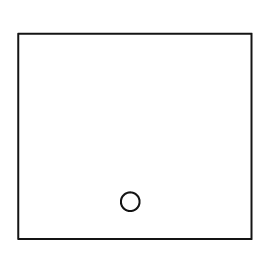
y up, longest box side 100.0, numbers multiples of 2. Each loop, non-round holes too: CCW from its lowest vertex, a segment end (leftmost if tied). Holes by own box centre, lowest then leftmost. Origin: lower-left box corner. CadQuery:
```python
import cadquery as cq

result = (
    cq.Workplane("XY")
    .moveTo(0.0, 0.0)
    .lineTo(100.0, 0.0)
    .lineTo(100.0, 88.0)
    .lineTo(0.0, 88.0)
    .close()
    .moveTo(48.0, 16.0)
    .circle(4.0)
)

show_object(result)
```